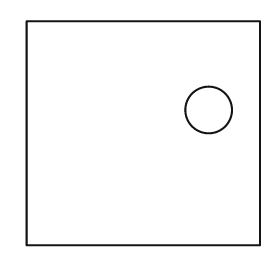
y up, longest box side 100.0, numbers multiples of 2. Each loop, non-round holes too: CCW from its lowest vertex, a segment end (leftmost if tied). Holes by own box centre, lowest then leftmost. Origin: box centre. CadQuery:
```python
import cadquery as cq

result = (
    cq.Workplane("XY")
    .moveTo(-50.0, -48.0)
    .lineTo(50.0, -48.0)
    .lineTo(50.0, 48.0)
    .lineTo(-50.0, 48.0)
    .close()
    .moveTo(28.0, 10.0)
    .circle(10.0)
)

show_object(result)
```